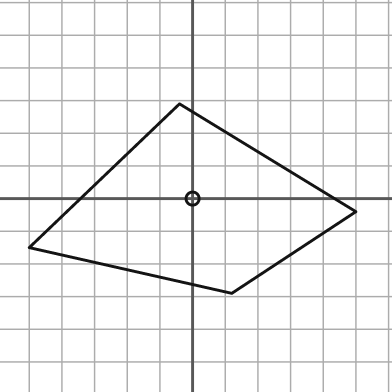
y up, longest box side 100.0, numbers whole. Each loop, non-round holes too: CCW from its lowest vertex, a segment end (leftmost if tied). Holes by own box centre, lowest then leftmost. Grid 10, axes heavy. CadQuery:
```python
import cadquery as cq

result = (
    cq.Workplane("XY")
    .moveTo(12.0, -29.0)
    .lineTo(50.0, -4.0)
    .lineTo(-4.0, 29.0)
    .lineTo(-50.0, -15.0)
    .close()
    .moveTo(0.0, 0.0)
    .circle(2.0)
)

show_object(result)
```